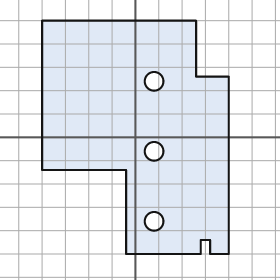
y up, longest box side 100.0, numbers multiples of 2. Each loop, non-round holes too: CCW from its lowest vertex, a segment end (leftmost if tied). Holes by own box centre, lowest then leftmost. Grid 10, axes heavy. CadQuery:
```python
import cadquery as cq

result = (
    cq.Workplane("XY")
    .moveTo(-4.0, -50.0)
    .lineTo(28.0, -50.0)
    .lineTo(28.0, -44.0)
    .lineTo(32.0, -44.0)
    .lineTo(32.0, -50.0)
    .lineTo(40.0, -50.0)
    .lineTo(40.0, 26.0)
    .lineTo(26.0, 26.0)
    .lineTo(26.0, 50.0)
    .lineTo(-40.0, 50.0)
    .lineTo(-40.0, -14.0)
    .lineTo(-4.0, -14.0)
    .close()
    .moveTo(8.0, -36.0)
    .circle(4.0)
    .moveTo(8.0, -6.0)
    .circle(4.0)
    .moveTo(8.0, 24.0)
    .circle(4.0)
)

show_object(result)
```